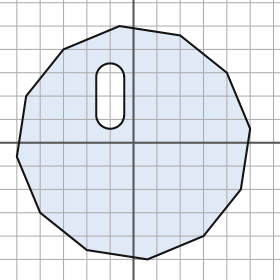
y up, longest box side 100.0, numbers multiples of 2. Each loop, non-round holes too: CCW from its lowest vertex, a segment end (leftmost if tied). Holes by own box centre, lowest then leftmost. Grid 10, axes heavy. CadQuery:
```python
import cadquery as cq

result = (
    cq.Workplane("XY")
    .moveTo(6.0, -50.0)
    .lineTo(30.0, -40.0)
    .lineTo(46.0, -20.0)
    .lineTo(50.0, 6.0)
    .lineTo(40.0, 30.0)
    .lineTo(20.0, 46.0)
    .lineTo(-6.0, 50.0)
    .lineTo(-30.0, 40.0)
    .lineTo(-46.0, 20.0)
    .lineTo(-50.0, -6.0)
    .lineTo(-40.0, -30.0)
    .lineTo(-20.0, -46.0)
    .close()
    .moveTo(-16.0, 12.0)
    .threePointArc((-10.0, 6.0), (-4.0, 12.0))
    .lineTo(-4.0, 28.0)
    .threePointArc((-10.0, 34.0), (-16.0, 28.0))
    .close()
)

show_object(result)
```